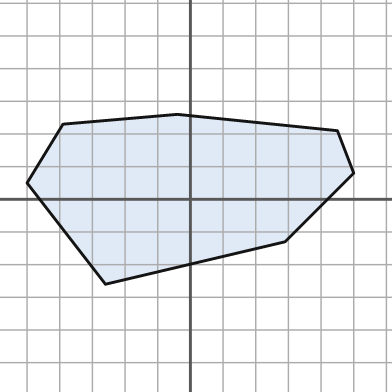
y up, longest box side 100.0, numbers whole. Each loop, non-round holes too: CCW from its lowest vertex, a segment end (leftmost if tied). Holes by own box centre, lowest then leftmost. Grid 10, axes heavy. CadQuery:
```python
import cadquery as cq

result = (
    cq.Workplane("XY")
    .moveTo(-26.0, -26.0)
    .lineTo(29.0, -13.0)
    .lineTo(50.0, 8.0)
    .lineTo(45.0, 21.0)
    .lineTo(-4.0, 26.0)
    .lineTo(-39.0, 23.0)
    .lineTo(-50.0, 5.0)
    .close()
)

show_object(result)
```